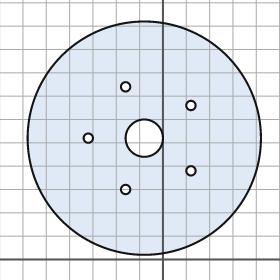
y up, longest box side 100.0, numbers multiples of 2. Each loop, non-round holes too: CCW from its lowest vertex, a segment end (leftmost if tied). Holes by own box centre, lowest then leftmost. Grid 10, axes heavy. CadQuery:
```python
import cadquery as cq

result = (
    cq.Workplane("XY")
    .moveTo(-8.0, 52.0)
    .circle(50.0)
    .moveTo(-16.0, 30.0)
    .circle(2.0)
    .moveTo(12.0, 38.0)
    .circle(2.0)
    .moveTo(-32.0, 52.0)
    .circle(2.0)
    .moveTo(-8.0, 52.0)
    .circle(8.0)
    .moveTo(12.0, 66.0)
    .circle(2.0)
    .moveTo(-16.0, 74.0)
    .circle(2.0)
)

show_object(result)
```